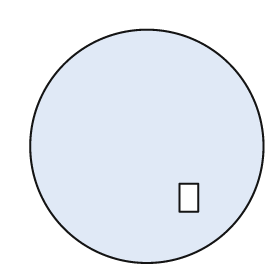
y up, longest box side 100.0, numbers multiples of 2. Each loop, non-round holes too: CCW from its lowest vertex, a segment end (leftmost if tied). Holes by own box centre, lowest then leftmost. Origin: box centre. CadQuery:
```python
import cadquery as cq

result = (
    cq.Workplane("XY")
    .moveTo(0.0, 0.0)
    .circle(50.0)
    .moveTo(14.0, -28.0)
    .lineTo(22.0, -28.0)
    .lineTo(22.0, -16.0)
    .lineTo(14.0, -16.0)
    .close()
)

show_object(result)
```